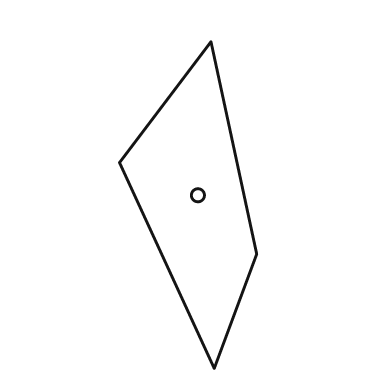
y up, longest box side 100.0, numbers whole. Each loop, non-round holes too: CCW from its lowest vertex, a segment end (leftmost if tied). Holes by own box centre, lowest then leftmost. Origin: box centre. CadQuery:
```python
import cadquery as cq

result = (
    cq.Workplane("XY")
    .moveTo(8.0, -50.0)
    .lineTo(21.0, -15.0)
    .lineTo(7.0, 50.0)
    .lineTo(-21.0, 13.0)
    .close()
    .moveTo(3.0, 3.0)
    .circle(2.0)
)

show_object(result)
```